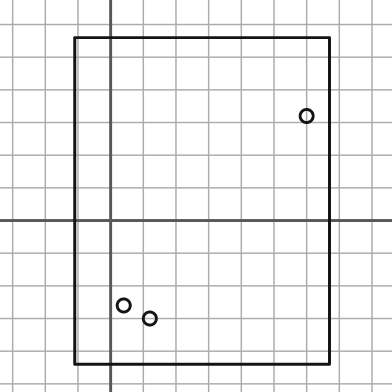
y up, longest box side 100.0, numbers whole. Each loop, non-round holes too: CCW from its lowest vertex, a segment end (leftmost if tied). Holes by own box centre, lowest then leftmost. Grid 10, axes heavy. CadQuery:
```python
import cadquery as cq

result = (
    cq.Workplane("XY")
    .moveTo(-11.0, -44.0)
    .lineTo(67.0, -44.0)
    .lineTo(67.0, 56.0)
    .lineTo(-11.0, 56.0)
    .close()
    .moveTo(12.0, -30.0)
    .circle(2.0)
    .moveTo(4.0, -26.0)
    .circle(2.0)
    .moveTo(60.0, 32.0)
    .circle(2.0)
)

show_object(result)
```